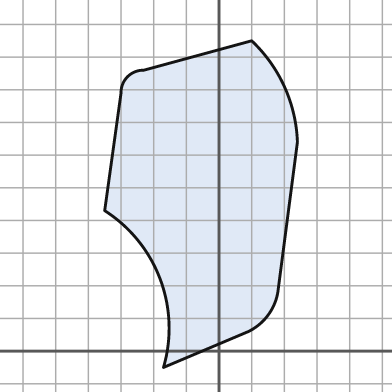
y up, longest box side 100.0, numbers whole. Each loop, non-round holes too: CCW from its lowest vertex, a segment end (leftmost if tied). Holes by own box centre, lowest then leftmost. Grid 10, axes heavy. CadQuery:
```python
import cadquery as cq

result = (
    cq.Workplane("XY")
    .moveTo(-17.0, -5.0)
    .lineTo(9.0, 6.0)
    .threePointArc((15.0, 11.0), (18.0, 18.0))
    .lineTo(24.0, 64.0)
    .threePointArc((20.0, 81.0), (10.0, 95.0))
    .lineTo(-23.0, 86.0)
    .threePointArc((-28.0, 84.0), (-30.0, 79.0))
    .lineTo(-35.0, 43.0)
    .threePointArc((-18.0, 22.0), (-17.0, -5.0))
    .close()
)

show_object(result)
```